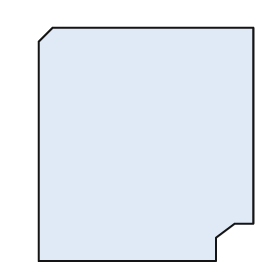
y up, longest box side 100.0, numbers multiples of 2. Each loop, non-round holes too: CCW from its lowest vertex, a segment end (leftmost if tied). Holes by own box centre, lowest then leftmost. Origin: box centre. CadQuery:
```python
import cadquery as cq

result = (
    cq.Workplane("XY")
    .moveTo(-46.0, -50.0)
    .lineTo(30.0, -50.0)
    .lineTo(30.0, -40.0)
    .lineTo(38.0, -34.0)
    .lineTo(46.0, -34.0)
    .lineTo(46.0, 50.0)
    .lineTo(-40.0, 50.0)
    .lineTo(-46.0, 44.0)
    .close()
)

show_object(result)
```